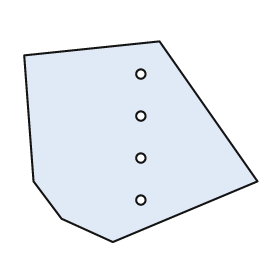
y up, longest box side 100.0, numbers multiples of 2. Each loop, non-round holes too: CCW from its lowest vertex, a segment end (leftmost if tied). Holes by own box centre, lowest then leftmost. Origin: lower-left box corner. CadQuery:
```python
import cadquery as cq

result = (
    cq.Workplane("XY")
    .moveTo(38.0, 0.0)
    .lineTo(100.0, 26.0)
    .lineTo(58.0, 86.0)
    .lineTo(0.0, 80.0)
    .lineTo(4.0, 26.0)
    .lineTo(16.0, 10.0)
    .close()
    .moveTo(50.0, 18.0)
    .circle(2.0)
    .moveTo(50.0, 36.0)
    .circle(2.0)
    .moveTo(50.0, 54.0)
    .circle(2.0)
    .moveTo(50.0, 72.0)
    .circle(2.0)
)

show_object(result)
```